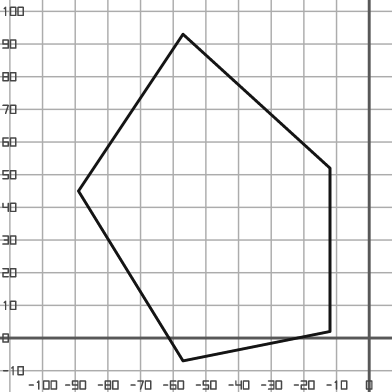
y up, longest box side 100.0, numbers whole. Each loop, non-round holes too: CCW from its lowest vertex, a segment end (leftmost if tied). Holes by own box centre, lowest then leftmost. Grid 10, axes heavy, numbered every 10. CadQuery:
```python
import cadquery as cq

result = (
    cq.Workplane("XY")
    .moveTo(-57.0, -7.0)
    .lineTo(-12.0, 2.0)
    .lineTo(-12.0, 52.0)
    .lineTo(-57.0, 93.0)
    .lineTo(-89.0, 45.0)
    .close()
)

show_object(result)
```